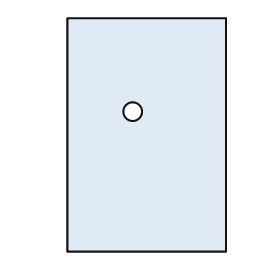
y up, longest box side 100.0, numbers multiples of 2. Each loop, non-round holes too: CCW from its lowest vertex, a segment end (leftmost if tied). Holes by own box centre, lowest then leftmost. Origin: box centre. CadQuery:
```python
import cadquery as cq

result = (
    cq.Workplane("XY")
    .moveTo(-34.0, -50.0)
    .lineTo(34.0, -50.0)
    .lineTo(34.0, 50.0)
    .lineTo(-34.0, 50.0)
    .close()
    .moveTo(-6.0, 10.0)
    .circle(4.0)
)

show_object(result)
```